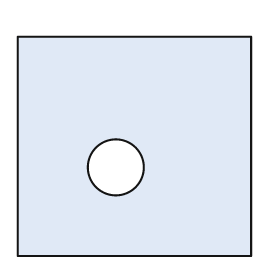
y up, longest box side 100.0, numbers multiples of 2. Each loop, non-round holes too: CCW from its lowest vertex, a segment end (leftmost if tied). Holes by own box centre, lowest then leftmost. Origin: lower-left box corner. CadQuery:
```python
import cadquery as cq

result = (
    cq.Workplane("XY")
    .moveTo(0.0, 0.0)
    .lineTo(100.0, 0.0)
    .lineTo(100.0, 94.0)
    .lineTo(0.0, 94.0)
    .close()
    .moveTo(42.0, 38.0)
    .circle(12.0)
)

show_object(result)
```